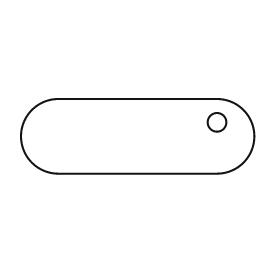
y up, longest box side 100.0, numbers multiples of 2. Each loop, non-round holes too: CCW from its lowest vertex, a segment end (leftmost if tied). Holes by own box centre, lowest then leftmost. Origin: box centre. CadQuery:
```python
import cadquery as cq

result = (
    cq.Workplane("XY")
    .moveTo(-34.0, -16.0)
    .lineTo(34.0, -16.0)
    .threePointArc((50.0, 0.0), (34.0, 16.0))
    .lineTo(-34.0, 16.0)
    .threePointArc((-50.0, 0.0), (-34.0, -16.0))
    .close()
    .moveTo(34.0, 6.0)
    .circle(4.0)
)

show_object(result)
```